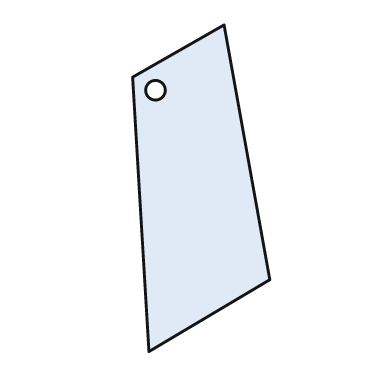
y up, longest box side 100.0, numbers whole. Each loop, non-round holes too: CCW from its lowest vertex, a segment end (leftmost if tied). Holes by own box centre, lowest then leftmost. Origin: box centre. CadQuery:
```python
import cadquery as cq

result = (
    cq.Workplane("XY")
    .moveTo(-16.0, -50.0)
    .lineTo(21.0, -28.0)
    .lineTo(7.0, 50.0)
    .lineTo(-21.0, 34.0)
    .close()
    .moveTo(-14.0, 30.0)
    .circle(3.0)
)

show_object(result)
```